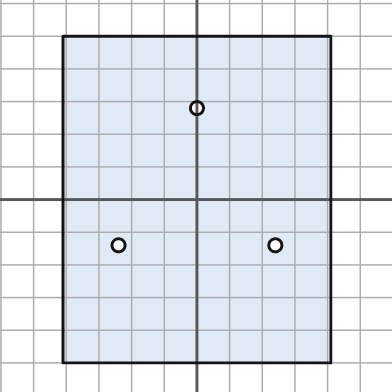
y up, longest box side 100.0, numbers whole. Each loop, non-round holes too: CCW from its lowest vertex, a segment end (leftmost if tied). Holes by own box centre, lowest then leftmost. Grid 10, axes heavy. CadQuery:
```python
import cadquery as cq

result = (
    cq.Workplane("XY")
    .moveTo(-41.0, -50.0)
    .lineTo(41.0, -50.0)
    .lineTo(41.0, 50.0)
    .lineTo(-41.0, 50.0)
    .close()
    .moveTo(-24.0, -14.0)
    .circle(2.0)
    .moveTo(24.0, -14.0)
    .circle(2.0)
    .moveTo(0.0, 28.0)
    .circle(2.0)
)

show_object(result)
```